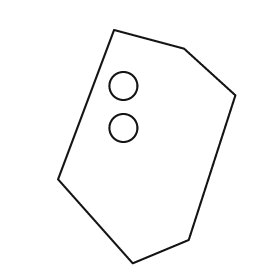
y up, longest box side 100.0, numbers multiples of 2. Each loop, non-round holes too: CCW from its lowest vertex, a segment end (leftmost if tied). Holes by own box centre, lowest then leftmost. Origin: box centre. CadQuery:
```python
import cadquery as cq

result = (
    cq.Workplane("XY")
    .moveTo(-6.0, -50.0)
    .lineTo(18.0, -40.0)
    .lineTo(38.0, 22.0)
    .lineTo(16.0, 42.0)
    .lineTo(-14.0, 50.0)
    .lineTo(-38.0, -14.0)
    .close()
    .moveTo(-10.0, 8.0)
    .circle(6.0)
    .moveTo(-10.0, 26.0)
    .circle(6.0)
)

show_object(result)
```